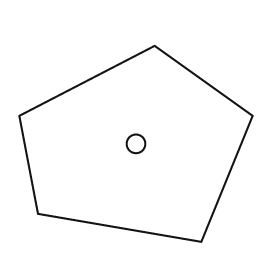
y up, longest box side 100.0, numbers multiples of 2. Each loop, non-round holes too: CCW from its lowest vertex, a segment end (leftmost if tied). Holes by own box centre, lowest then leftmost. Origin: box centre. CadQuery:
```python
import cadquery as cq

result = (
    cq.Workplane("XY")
    .moveTo(28.0, -42.0)
    .lineTo(50.0, 12.0)
    .lineTo(8.0, 42.0)
    .lineTo(-50.0, 12.0)
    .lineTo(-42.0, -30.0)
    .close()
    .moveTo(0.0, 0.0)
    .circle(4.0)
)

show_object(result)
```